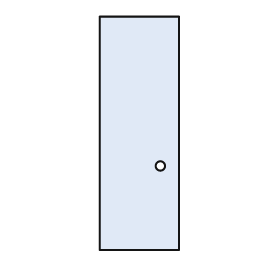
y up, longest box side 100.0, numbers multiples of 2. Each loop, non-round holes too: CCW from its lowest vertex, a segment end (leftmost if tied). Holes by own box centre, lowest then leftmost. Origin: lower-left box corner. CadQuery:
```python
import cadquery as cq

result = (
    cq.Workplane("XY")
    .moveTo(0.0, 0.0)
    .lineTo(34.0, 0.0)
    .lineTo(34.0, 100.0)
    .lineTo(0.0, 100.0)
    .close()
    .moveTo(26.0, 36.0)
    .circle(2.0)
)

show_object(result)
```